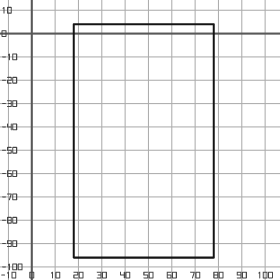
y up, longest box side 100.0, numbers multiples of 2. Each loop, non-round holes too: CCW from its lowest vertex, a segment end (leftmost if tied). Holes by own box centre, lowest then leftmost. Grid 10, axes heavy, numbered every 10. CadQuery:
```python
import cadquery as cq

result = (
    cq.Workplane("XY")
    .moveTo(18.0, -96.0)
    .lineTo(78.0, -96.0)
    .lineTo(78.0, 4.0)
    .lineTo(18.0, 4.0)
    .close()
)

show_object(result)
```